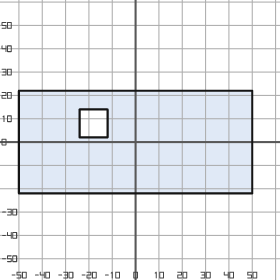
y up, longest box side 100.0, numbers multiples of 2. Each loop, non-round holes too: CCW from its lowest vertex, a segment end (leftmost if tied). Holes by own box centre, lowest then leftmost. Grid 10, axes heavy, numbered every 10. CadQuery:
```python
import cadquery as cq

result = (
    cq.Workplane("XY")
    .moveTo(-50.0, -22.0)
    .lineTo(50.0, -22.0)
    .lineTo(50.0, 22.0)
    .lineTo(-50.0, 22.0)
    .close()
    .moveTo(-24.0, 2.0)
    .lineTo(-12.0, 2.0)
    .lineTo(-12.0, 14.0)
    .lineTo(-24.0, 14.0)
    .close()
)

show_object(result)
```